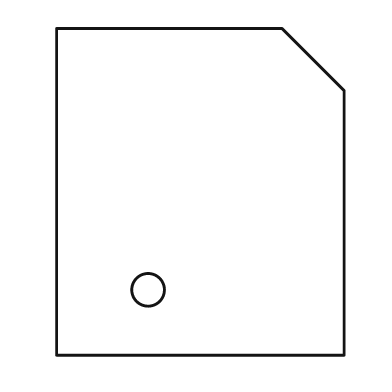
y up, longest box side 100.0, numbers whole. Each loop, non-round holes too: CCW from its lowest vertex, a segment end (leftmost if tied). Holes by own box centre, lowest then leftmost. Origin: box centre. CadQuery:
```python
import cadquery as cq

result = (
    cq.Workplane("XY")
    .moveTo(-44.0, -50.0)
    .lineTo(44.0, -50.0)
    .lineTo(44.0, 31.0)
    .lineTo(25.0, 50.0)
    .lineTo(-44.0, 50.0)
    .close()
    .moveTo(-16.0, -30.0)
    .circle(5.0)
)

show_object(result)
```